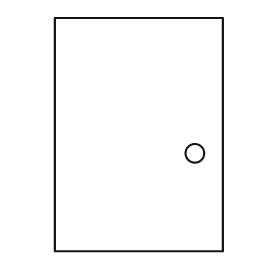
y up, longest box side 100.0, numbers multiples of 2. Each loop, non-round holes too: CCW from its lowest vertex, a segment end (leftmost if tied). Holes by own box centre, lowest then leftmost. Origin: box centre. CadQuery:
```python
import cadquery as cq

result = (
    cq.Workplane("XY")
    .moveTo(-36.0, -50.0)
    .lineTo(36.0, -50.0)
    .lineTo(36.0, 50.0)
    .lineTo(-36.0, 50.0)
    .close()
    .moveTo(24.0, -8.0)
    .circle(4.0)
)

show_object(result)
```